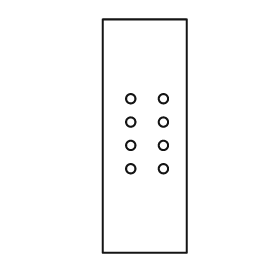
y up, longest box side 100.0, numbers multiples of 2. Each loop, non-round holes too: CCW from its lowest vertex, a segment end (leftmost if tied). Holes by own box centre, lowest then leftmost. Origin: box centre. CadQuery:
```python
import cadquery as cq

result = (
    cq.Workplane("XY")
    .moveTo(-18.0, -50.0)
    .lineTo(18.0, -50.0)
    .lineTo(18.0, 50.0)
    .lineTo(-18.0, 50.0)
    .close()
    .moveTo(-6.0, -14.0)
    .circle(2.0)
    .moveTo(8.0, -14.0)
    .circle(2.0)
    .moveTo(-6.0, -4.0)
    .circle(2.0)
    .moveTo(8.0, -4.0)
    .circle(2.0)
    .moveTo(-6.0, 6.0)
    .circle(2.0)
    .moveTo(8.0, 6.0)
    .circle(2.0)
    .moveTo(-6.0, 16.0)
    .circle(2.0)
    .moveTo(8.0, 16.0)
    .circle(2.0)
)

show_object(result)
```